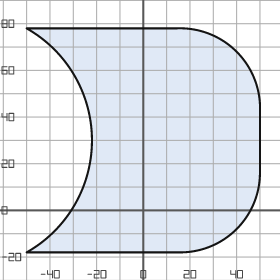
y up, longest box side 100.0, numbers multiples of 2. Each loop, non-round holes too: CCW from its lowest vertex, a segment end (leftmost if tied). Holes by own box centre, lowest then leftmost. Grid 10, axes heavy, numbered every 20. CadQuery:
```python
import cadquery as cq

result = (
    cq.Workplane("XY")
    .moveTo(-50.0, -18.0)
    .lineTo(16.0, -18.0)
    .threePointArc((40.0, -8.0), (50.0, 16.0))
    .lineTo(50.0, 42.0)
    .threePointArc((40.0, 68.0), (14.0, 78.0))
    .lineTo(-50.0, 78.0)
    .threePointArc((-22.0, 30.0), (-50.0, -18.0))
    .close()
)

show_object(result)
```